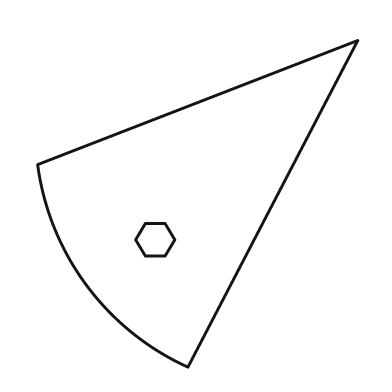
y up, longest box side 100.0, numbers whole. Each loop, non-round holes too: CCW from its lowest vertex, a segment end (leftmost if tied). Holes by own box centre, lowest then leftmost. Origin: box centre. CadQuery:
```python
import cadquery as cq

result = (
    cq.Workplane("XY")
    .moveTo(-3.0, -50.0)
    .lineTo(49.0, 50.0)
    .lineTo(-49.0, 12.0)
    .threePointArc((-34.0, -25.0), (-3.0, -50.0))
    .close()
    .moveTo(-16.0, -16.0)
    .lineTo(-10.0, -16.0)
    .lineTo(-7.0, -11.0)
    .lineTo(-10.0, -6.0)
    .lineTo(-16.0, -6.0)
    .lineTo(-19.0, -11.0)
    .close()
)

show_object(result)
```